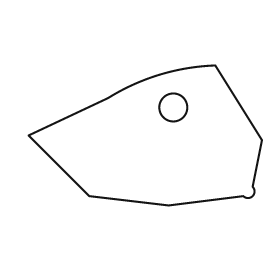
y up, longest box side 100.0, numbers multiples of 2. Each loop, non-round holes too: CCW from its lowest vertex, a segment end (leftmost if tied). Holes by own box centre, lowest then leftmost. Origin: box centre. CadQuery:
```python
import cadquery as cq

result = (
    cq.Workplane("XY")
    .moveTo(10.0, -30.0)
    .lineTo(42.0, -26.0)
    .threePointArc((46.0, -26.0), (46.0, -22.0))
    .lineTo(50.0, -2.0)
    .lineTo(30.0, 30.0)
    .threePointArc((6.0, 26.0), (-16.0, 16.0))
    .lineTo(-50.0, 0.0)
    .lineTo(-24.0, -26.0)
    .close()
    .moveTo(12.0, 12.0)
    .circle(6.0)
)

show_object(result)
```